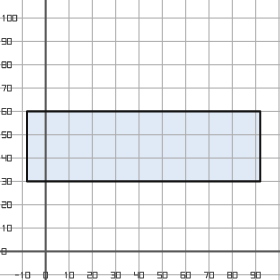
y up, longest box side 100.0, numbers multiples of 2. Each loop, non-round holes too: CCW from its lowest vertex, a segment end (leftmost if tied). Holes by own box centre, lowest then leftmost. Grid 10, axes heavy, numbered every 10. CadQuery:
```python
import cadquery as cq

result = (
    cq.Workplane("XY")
    .moveTo(-8.0, 30.0)
    .lineTo(92.0, 30.0)
    .lineTo(92.0, 60.0)
    .lineTo(-8.0, 60.0)
    .close()
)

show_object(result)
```